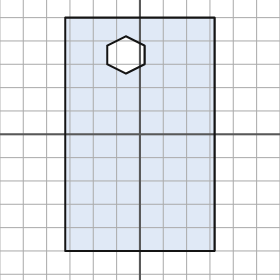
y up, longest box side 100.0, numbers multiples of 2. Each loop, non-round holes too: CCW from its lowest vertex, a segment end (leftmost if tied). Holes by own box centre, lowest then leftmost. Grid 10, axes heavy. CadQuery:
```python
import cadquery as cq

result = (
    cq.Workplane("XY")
    .moveTo(-32.0, -50.0)
    .lineTo(32.0, -50.0)
    .lineTo(32.0, 50.0)
    .lineTo(-32.0, 50.0)
    .close()
    .moveTo(-6.0, 26.0)
    .lineTo(2.0, 30.0)
    .lineTo(2.0, 38.0)
    .lineTo(-6.0, 42.0)
    .lineTo(-14.0, 38.0)
    .lineTo(-14.0, 30.0)
    .close()
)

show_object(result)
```